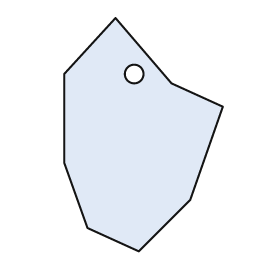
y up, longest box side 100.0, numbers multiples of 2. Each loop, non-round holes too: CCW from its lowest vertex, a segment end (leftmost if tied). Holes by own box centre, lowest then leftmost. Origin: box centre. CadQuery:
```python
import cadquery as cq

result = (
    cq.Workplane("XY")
    .moveTo(-2.0, -50.0)
    .lineTo(20.0, -28.0)
    .lineTo(34.0, 12.0)
    .lineTo(12.0, 22.0)
    .lineTo(-12.0, 50.0)
    .lineTo(-34.0, 26.0)
    .lineTo(-34.0, -12.0)
    .lineTo(-24.0, -40.0)
    .close()
    .moveTo(-4.0, 26.0)
    .circle(4.0)
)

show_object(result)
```